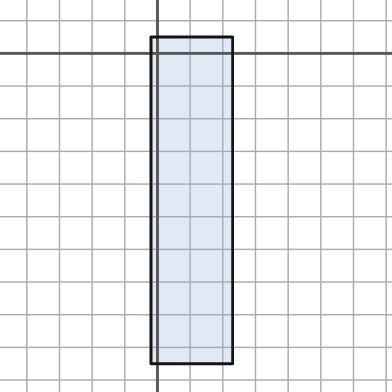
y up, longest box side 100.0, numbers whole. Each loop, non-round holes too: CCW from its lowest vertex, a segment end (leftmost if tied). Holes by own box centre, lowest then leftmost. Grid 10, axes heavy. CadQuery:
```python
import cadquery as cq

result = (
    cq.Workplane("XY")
    .moveTo(-2.0, -95.0)
    .lineTo(23.0, -95.0)
    .lineTo(23.0, 5.0)
    .lineTo(-2.0, 5.0)
    .close()
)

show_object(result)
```